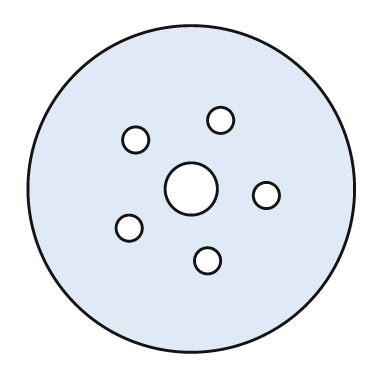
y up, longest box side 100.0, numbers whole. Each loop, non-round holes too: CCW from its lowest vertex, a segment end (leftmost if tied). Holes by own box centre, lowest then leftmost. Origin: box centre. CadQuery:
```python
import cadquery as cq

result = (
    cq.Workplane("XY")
    .moveTo(0.0, 0.0)
    .circle(50.0)
    .moveTo(5.0, -22.0)
    .circle(4.0)
    .moveTo(-19.0, -12.0)
    .circle(4.0)
    .moveTo(23.0, -2.0)
    .circle(4.0)
    .moveTo(0.0, 0.0)
    .circle(8.0)
    .moveTo(-17.0, 15.0)
    .circle(4.0)
    .moveTo(9.0, 21.0)
    .circle(4.0)
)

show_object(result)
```